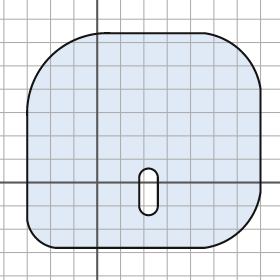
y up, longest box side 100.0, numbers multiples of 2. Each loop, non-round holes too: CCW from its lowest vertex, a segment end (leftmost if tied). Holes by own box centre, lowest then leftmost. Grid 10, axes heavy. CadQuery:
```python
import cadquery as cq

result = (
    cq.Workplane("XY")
    .moveTo(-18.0, -28.0)
    .lineTo(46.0, -28.0)
    .threePointArc((62.0, -20.0), (70.0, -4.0))
    .lineTo(70.0, 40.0)
    .threePointArc((62.0, 56.0), (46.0, 64.0))
    .lineTo(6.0, 64.0)
    .threePointArc((-20.0, 54.0), (-30.0, 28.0))
    .lineTo(-30.0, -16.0)
    .threePointArc((-26.0, -24.0), (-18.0, -28.0))
    .close()
    .moveTo(18.0, -10.0)
    .threePointArc((22.0, -14.0), (26.0, -10.0))
    .lineTo(26.0, 2.0)
    .threePointArc((22.0, 6.0), (18.0, 2.0))
    .close()
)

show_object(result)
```